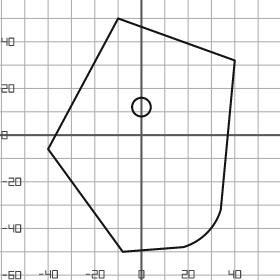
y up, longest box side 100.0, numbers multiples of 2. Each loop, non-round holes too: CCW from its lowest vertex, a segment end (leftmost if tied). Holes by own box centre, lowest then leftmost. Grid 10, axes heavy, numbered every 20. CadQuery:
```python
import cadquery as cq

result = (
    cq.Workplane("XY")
    .moveTo(-8.0, -50.0)
    .lineTo(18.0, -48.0)
    .threePointArc((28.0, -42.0), (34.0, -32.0))
    .lineTo(40.0, 32.0)
    .lineTo(-10.0, 50.0)
    .lineTo(-40.0, -6.0)
    .close()
    .moveTo(0.0, 12.0)
    .circle(4.0)
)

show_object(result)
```